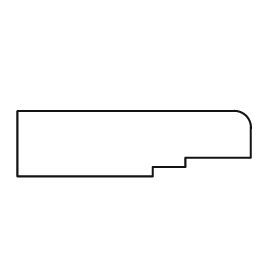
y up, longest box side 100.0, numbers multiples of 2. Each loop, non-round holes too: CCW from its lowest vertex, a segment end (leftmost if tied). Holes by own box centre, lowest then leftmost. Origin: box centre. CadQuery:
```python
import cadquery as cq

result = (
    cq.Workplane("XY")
    .moveTo(-50.0, -14.0)
    .lineTo(8.0, -14.0)
    .lineTo(8.0, -10.0)
    .lineTo(22.0, -10.0)
    .lineTo(22.0, -6.0)
    .lineTo(50.0, -6.0)
    .lineTo(50.0, 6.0)
    .threePointArc((48.0, 12.0), (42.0, 14.0))
    .lineTo(-50.0, 14.0)
    .close()
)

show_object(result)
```